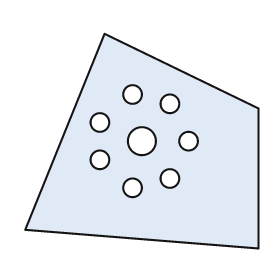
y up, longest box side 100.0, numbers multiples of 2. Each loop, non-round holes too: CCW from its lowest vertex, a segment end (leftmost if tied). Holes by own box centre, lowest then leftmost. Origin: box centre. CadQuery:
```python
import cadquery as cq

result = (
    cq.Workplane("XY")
    .moveTo(50.0, -46.0)
    .lineTo(50.0, 14.0)
    .lineTo(-16.0, 46.0)
    .lineTo(-50.0, -38.0)
    .close()
    .moveTo(-4.0, -20.0)
    .circle(4.0)
    .moveTo(12.0, -16.0)
    .circle(4.0)
    .moveTo(-18.0, -8.0)
    .circle(4.0)
    .moveTo(0.0, 0.0)
    .circle(6.0)
    .moveTo(20.0, 0.0)
    .circle(4.0)
    .moveTo(-18.0, 8.0)
    .circle(4.0)
    .moveTo(12.0, 16.0)
    .circle(4.0)
    .moveTo(-4.0, 20.0)
    .circle(4.0)
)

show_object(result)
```